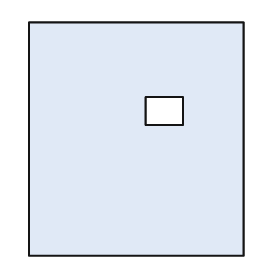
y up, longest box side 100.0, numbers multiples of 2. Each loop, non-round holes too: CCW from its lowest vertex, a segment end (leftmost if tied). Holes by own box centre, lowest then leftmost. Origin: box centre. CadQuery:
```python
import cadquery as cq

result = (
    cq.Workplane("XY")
    .moveTo(-46.0, -50.0)
    .lineTo(46.0, -50.0)
    .lineTo(46.0, 50.0)
    .lineTo(-46.0, 50.0)
    .close()
    .moveTo(4.0, 6.0)
    .lineTo(20.0, 6.0)
    .lineTo(20.0, 18.0)
    .lineTo(4.0, 18.0)
    .close()
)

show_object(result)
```